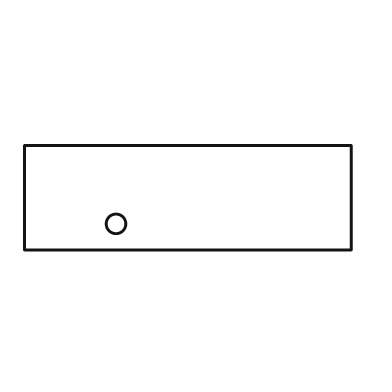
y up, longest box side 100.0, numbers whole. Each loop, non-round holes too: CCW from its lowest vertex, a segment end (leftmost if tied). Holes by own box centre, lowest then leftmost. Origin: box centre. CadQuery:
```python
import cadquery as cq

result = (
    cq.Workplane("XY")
    .moveTo(-50.0, -16.0)
    .lineTo(50.0, -16.0)
    .lineTo(50.0, 16.0)
    .lineTo(-50.0, 16.0)
    .close()
    .moveTo(-22.0, -8.0)
    .circle(3.0)
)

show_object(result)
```